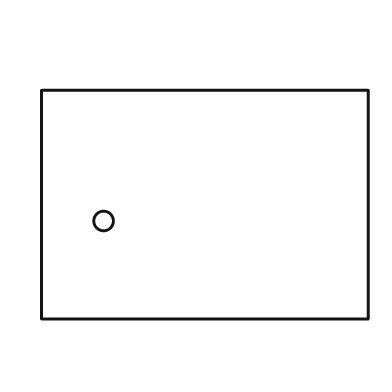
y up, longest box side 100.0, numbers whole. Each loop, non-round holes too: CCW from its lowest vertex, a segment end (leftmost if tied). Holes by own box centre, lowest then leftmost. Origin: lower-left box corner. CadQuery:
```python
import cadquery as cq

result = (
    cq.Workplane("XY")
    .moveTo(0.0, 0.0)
    .lineTo(100.0, 0.0)
    .lineTo(100.0, 70.0)
    .lineTo(0.0, 70.0)
    .close()
    .moveTo(19.0, 30.0)
    .circle(3.0)
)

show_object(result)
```